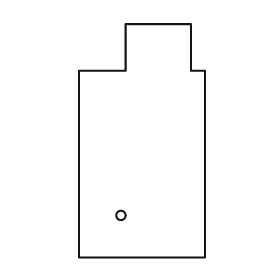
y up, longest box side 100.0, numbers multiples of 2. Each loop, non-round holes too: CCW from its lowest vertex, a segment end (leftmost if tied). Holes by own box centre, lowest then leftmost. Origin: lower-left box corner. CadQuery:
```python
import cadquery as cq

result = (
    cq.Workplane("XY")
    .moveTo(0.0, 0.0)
    .lineTo(54.0, 0.0)
    .lineTo(54.0, 80.0)
    .lineTo(48.0, 80.0)
    .lineTo(48.0, 100.0)
    .lineTo(20.0, 100.0)
    .lineTo(20.0, 80.0)
    .lineTo(0.0, 80.0)
    .close()
    .moveTo(18.0, 18.0)
    .circle(2.0)
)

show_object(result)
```